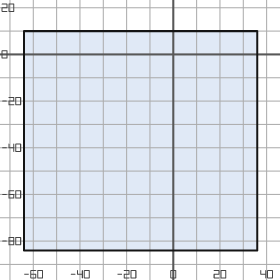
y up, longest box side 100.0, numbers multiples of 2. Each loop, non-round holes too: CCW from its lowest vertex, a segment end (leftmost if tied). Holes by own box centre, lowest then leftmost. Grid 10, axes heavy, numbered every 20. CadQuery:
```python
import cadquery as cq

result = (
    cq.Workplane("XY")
    .moveTo(-64.0, -84.0)
    .lineTo(36.0, -84.0)
    .lineTo(36.0, 10.0)
    .lineTo(-64.0, 10.0)
    .close()
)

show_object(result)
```